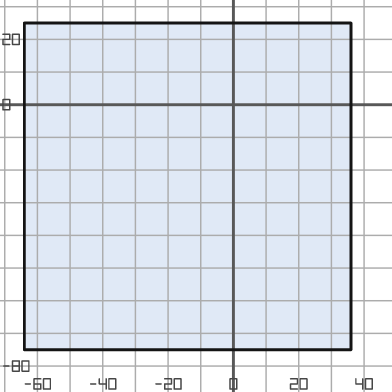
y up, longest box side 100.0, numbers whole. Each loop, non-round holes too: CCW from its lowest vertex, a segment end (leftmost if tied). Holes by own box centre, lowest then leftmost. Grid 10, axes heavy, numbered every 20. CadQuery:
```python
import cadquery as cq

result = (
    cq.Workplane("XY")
    .moveTo(-64.0, -75.0)
    .lineTo(36.0, -75.0)
    .lineTo(36.0, 25.0)
    .lineTo(-64.0, 25.0)
    .close()
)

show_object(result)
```